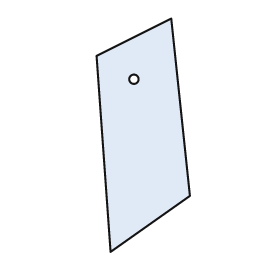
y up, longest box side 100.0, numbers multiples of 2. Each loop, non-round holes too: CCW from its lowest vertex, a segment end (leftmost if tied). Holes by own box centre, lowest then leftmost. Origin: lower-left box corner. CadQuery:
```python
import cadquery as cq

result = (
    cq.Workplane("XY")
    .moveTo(6.0, 0.0)
    .lineTo(40.0, 24.0)
    .lineTo(32.0, 100.0)
    .lineTo(0.0, 84.0)
    .close()
    .moveTo(16.0, 74.0)
    .circle(2.0)
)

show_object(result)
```